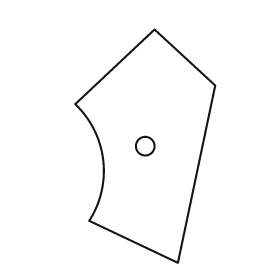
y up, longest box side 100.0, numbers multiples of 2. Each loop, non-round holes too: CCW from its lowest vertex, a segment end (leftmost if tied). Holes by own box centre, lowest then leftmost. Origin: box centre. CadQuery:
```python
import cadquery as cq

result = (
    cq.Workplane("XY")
    .moveTo(14.0, -50.0)
    .lineTo(30.0, 26.0)
    .lineTo(4.0, 50.0)
    .lineTo(-30.0, 18.0)
    .threePointArc((-18.0, -6.0), (-24.0, -32.0))
    .close()
    .moveTo(0.0, 0.0)
    .circle(4.0)
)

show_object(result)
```